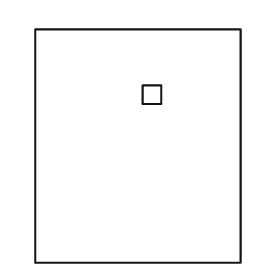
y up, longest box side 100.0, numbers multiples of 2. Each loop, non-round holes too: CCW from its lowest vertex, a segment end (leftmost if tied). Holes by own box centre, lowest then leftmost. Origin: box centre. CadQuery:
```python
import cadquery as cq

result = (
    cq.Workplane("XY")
    .moveTo(-44.0, -50.0)
    .lineTo(44.0, -50.0)
    .lineTo(44.0, 50.0)
    .lineTo(-44.0, 50.0)
    .close()
    .moveTo(2.0, 18.0)
    .lineTo(10.0, 18.0)
    .lineTo(10.0, 26.0)
    .lineTo(2.0, 26.0)
    .close()
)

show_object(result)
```